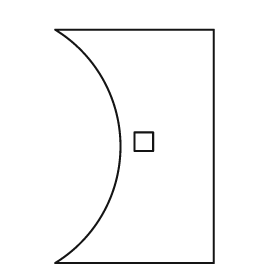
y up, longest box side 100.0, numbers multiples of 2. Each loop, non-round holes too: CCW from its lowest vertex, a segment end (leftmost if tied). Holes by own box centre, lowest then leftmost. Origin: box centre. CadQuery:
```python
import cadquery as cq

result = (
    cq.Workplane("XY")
    .moveTo(-34.0, -50.0)
    .lineTo(34.0, -50.0)
    .lineTo(34.0, 50.0)
    .lineTo(-34.0, 50.0)
    .threePointArc((-6.0, 0.0), (-34.0, -50.0))
    .close()
    .moveTo(0.0, -2.0)
    .lineTo(8.0, -2.0)
    .lineTo(8.0, 6.0)
    .lineTo(0.0, 6.0)
    .close()
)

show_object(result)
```